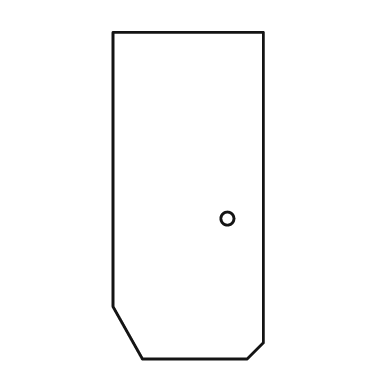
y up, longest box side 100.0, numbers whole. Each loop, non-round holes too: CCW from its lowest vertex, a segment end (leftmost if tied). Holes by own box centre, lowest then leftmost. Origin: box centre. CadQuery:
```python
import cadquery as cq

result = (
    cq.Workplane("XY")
    .moveTo(-14.0, -50.0)
    .lineTo(18.0, -50.0)
    .lineTo(23.0, -45.0)
    .lineTo(23.0, 50.0)
    .lineTo(-23.0, 50.0)
    .lineTo(-23.0, -34.0)
    .close()
    .moveTo(12.0, -7.0)
    .circle(2.0)
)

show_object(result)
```